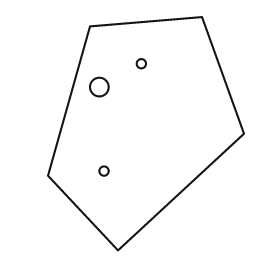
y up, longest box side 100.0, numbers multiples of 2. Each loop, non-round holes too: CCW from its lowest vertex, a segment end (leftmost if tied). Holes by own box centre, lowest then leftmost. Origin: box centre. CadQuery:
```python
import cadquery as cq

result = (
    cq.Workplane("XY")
    .moveTo(-12.0, -50.0)
    .lineTo(42.0, 0.0)
    .lineTo(24.0, 50.0)
    .lineTo(-24.0, 46.0)
    .lineTo(-42.0, -18.0)
    .close()
    .moveTo(-18.0, -16.0)
    .circle(2.0)
    .moveTo(-20.0, 20.0)
    .circle(4.0)
    .moveTo(-2.0, 30.0)
    .circle(2.0)
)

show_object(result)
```